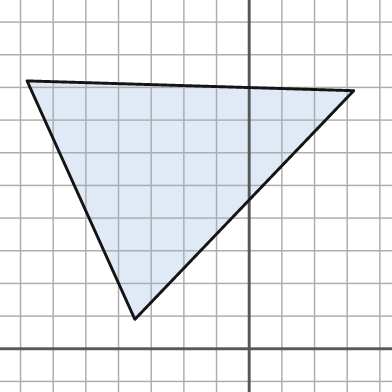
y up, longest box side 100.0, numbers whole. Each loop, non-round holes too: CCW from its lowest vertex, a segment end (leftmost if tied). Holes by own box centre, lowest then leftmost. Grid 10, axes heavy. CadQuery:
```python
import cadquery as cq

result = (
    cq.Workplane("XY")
    .moveTo(-35.0, 9.0)
    .lineTo(32.0, 79.0)
    .lineTo(-68.0, 82.0)
    .close()
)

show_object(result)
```